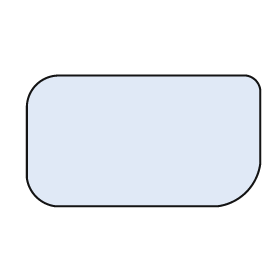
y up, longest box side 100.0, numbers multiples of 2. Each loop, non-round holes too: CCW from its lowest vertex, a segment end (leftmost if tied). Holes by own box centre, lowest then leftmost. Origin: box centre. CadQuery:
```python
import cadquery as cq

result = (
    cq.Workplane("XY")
    .moveTo(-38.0, -28.0)
    .lineTo(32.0, -28.0)
    .threePointArc((44.0, -22.0), (50.0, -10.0))
    .lineTo(50.0, 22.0)
    .threePointArc((48.0, 26.0), (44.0, 28.0))
    .lineTo(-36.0, 28.0)
    .threePointArc((-46.0, 24.0), (-50.0, 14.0))
    .lineTo(-50.0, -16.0)
    .threePointArc((-46.0, -24.0), (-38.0, -28.0))
    .close()
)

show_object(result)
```